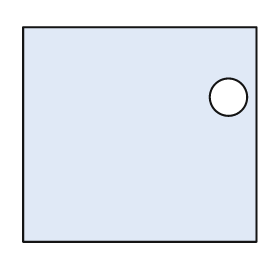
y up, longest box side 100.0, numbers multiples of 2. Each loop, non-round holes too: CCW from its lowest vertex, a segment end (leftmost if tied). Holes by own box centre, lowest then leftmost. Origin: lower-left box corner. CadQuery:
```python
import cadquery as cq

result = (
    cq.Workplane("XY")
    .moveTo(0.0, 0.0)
    .lineTo(100.0, 0.0)
    .lineTo(100.0, 92.0)
    .lineTo(0.0, 92.0)
    .close()
    .moveTo(88.0, 62.0)
    .circle(8.0)
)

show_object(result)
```